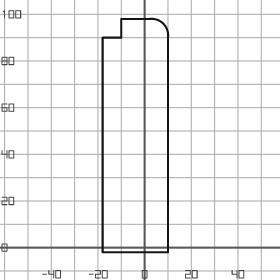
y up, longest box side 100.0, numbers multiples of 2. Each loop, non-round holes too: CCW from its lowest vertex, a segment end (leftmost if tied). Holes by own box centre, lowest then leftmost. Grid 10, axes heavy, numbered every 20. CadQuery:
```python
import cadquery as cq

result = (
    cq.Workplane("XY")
    .moveTo(-18.0, -2.0)
    .lineTo(10.0, -2.0)
    .lineTo(10.0, 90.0)
    .threePointArc((8.0, 96.0), (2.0, 98.0))
    .lineTo(-10.0, 98.0)
    .lineTo(-10.0, 90.0)
    .lineTo(-18.0, 90.0)
    .close()
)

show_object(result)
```